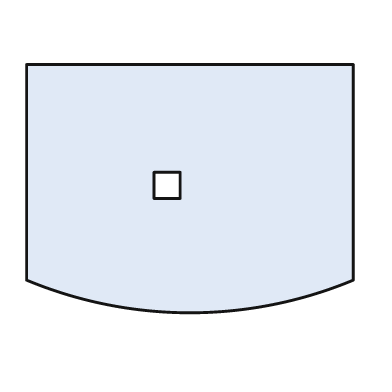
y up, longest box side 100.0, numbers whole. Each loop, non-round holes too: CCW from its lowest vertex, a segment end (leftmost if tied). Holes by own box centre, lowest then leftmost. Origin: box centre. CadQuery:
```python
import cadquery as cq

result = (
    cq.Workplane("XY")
    .moveTo(-50.0, -28.0)
    .threePointArc((0.0, -38.0), (50.0, -28.0))
    .lineTo(50.0, 38.0)
    .lineTo(-50.0, 38.0)
    .close()
    .moveTo(-11.0, -3.0)
    .lineTo(-3.0, -3.0)
    .lineTo(-3.0, 5.0)
    .lineTo(-11.0, 5.0)
    .close()
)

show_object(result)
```